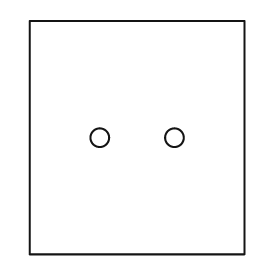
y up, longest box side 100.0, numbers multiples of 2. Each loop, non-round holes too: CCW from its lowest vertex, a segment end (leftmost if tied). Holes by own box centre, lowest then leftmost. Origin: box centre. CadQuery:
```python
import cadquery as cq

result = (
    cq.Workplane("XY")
    .moveTo(-46.0, -50.0)
    .lineTo(46.0, -50.0)
    .lineTo(46.0, 50.0)
    .lineTo(-46.0, 50.0)
    .close()
    .moveTo(-16.0, 0.0)
    .circle(4.0)
    .moveTo(16.0, 0.0)
    .circle(4.0)
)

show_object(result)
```